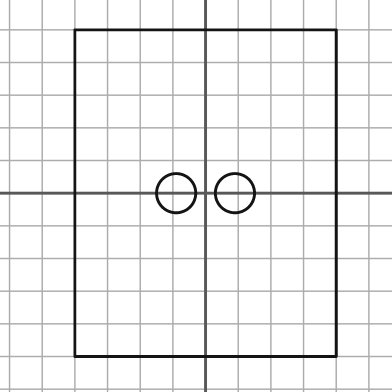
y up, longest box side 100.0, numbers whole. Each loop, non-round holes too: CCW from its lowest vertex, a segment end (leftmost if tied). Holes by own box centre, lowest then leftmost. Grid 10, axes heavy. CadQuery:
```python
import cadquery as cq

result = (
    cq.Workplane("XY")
    .moveTo(-40.0, -50.0)
    .lineTo(40.0, -50.0)
    .lineTo(40.0, 50.0)
    .lineTo(-40.0, 50.0)
    .close()
    .moveTo(-9.0, 0.0)
    .circle(6.0)
    .moveTo(9.0, 0.0)
    .circle(6.0)
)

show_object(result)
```